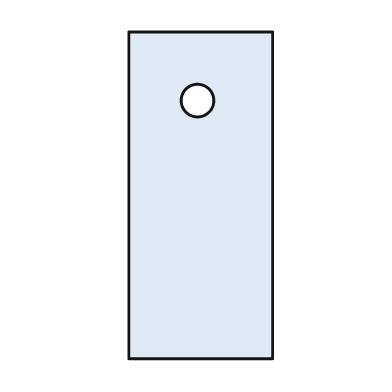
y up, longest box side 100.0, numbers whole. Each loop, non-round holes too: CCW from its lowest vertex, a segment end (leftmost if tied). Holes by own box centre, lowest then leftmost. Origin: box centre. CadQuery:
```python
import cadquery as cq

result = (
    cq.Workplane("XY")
    .moveTo(-22.0, -50.0)
    .lineTo(22.0, -50.0)
    .lineTo(22.0, 50.0)
    .lineTo(-22.0, 50.0)
    .close()
    .moveTo(-1.0, 29.0)
    .circle(5.0)
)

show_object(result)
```